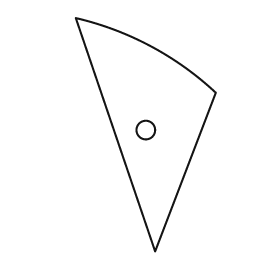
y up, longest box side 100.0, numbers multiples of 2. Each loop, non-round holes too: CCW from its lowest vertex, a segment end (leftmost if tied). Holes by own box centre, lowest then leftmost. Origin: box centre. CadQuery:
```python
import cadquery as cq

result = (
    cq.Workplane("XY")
    .moveTo(4.0, -50.0)
    .lineTo(30.0, 18.0)
    .threePointArc((2.0, 38.0), (-30.0, 50.0))
    .close()
    .moveTo(0.0, 2.0)
    .circle(4.0)
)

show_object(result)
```